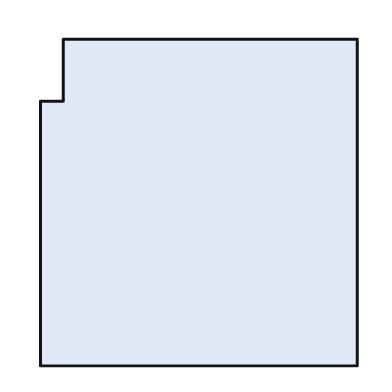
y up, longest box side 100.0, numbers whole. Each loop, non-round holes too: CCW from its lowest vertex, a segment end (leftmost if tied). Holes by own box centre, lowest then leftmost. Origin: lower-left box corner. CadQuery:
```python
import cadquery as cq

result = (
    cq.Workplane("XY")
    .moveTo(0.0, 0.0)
    .lineTo(97.0, 0.0)
    .lineTo(97.0, 100.0)
    .lineTo(7.0, 100.0)
    .lineTo(7.0, 81.0)
    .lineTo(0.0, 81.0)
    .close()
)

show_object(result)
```